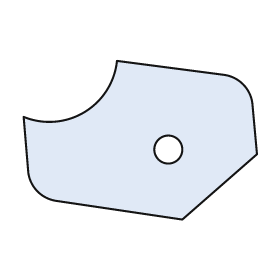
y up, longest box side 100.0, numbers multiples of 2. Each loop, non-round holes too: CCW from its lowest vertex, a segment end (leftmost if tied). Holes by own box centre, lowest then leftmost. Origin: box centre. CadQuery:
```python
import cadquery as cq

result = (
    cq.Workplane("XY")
    .moveTo(18.0, -34.0)
    .lineTo(50.0, -6.0)
    .lineTo(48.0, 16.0)
    .threePointArc((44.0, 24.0), (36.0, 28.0))
    .lineTo(-10.0, 34.0)
    .threePointArc((-24.0, 12.0), (-50.0, 10.0))
    .lineTo(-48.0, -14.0)
    .threePointArc((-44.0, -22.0), (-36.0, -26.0))
    .close()
    .moveTo(12.0, -4.0)
    .circle(6.0)
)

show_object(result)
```